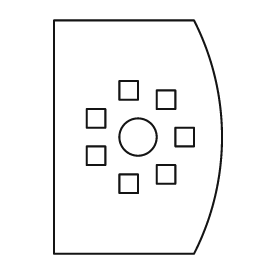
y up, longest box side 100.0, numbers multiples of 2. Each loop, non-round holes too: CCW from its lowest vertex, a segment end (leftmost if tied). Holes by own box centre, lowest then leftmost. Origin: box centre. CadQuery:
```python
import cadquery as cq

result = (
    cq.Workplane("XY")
    .moveTo(-36.0, -50.0)
    .lineTo(24.0, -50.0)
    .threePointArc((36.0, 0.0), (24.0, 50.0))
    .lineTo(-36.0, 50.0)
    .close()
    .moveTo(-8.0, -24.0)
    .lineTo(0.0, -24.0)
    .lineTo(0.0, -16.0)
    .lineTo(-8.0, -16.0)
    .close()
    .moveTo(8.0, -20.0)
    .lineTo(16.0, -20.0)
    .lineTo(16.0, -12.0)
    .lineTo(8.0, -12.0)
    .close()
    .moveTo(-22.0, -12.0)
    .lineTo(-14.0, -12.0)
    .lineTo(-14.0, -4.0)
    .lineTo(-22.0, -4.0)
    .close()
    .moveTo(0.0, 0.0)
    .circle(8.0)
    .moveTo(16.0, -4.0)
    .lineTo(24.0, -4.0)
    .lineTo(24.0, 4.0)
    .lineTo(16.0, 4.0)
    .close()
    .moveTo(-22.0, 4.0)
    .lineTo(-14.0, 4.0)
    .lineTo(-14.0, 12.0)
    .lineTo(-22.0, 12.0)
    .close()
    .moveTo(8.0, 12.0)
    .lineTo(16.0, 12.0)
    .lineTo(16.0, 20.0)
    .lineTo(8.0, 20.0)
    .close()
    .moveTo(-8.0, 16.0)
    .lineTo(0.0, 16.0)
    .lineTo(0.0, 24.0)
    .lineTo(-8.0, 24.0)
    .close()
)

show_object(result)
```